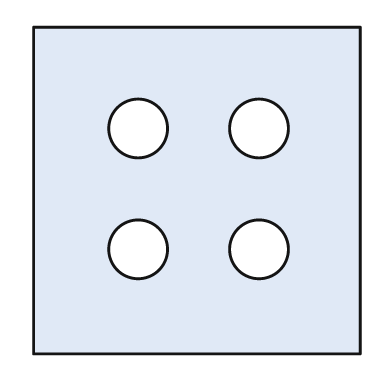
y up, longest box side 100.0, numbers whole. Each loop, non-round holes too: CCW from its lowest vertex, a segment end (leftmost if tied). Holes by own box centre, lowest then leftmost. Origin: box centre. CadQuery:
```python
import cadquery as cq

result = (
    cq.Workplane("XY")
    .moveTo(-50.0, -50.0)
    .lineTo(50.0, -50.0)
    .lineTo(50.0, 50.0)
    .lineTo(-50.0, 50.0)
    .close()
    .moveTo(-18.0, -18.0)
    .circle(9.0)
    .moveTo(19.0, -18.0)
    .circle(9.0)
    .moveTo(-18.0, 19.0)
    .circle(9.0)
    .moveTo(19.0, 19.0)
    .circle(9.0)
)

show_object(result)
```